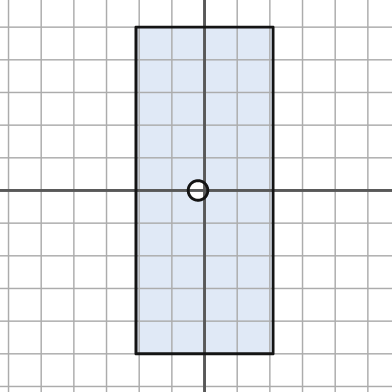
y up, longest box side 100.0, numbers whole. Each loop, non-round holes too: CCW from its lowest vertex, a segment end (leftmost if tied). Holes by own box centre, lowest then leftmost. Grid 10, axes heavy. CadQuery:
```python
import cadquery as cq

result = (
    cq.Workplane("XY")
    .moveTo(-21.0, -50.0)
    .lineTo(21.0, -50.0)
    .lineTo(21.0, 50.0)
    .lineTo(-21.0, 50.0)
    .close()
    .moveTo(-2.0, 0.0)
    .circle(3.0)
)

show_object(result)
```